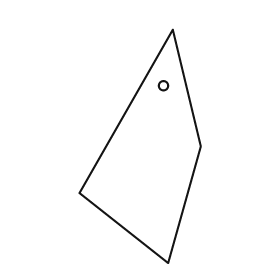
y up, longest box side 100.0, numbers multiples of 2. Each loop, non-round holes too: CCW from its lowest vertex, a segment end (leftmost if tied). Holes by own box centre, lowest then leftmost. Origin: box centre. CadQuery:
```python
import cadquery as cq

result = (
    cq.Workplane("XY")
    .moveTo(12.0, -50.0)
    .lineTo(26.0, 0.0)
    .lineTo(14.0, 50.0)
    .lineTo(-26.0, -20.0)
    .close()
    .moveTo(10.0, 26.0)
    .circle(2.0)
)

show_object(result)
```